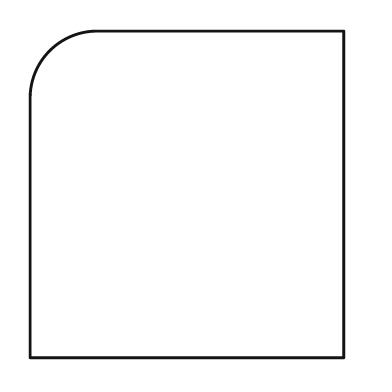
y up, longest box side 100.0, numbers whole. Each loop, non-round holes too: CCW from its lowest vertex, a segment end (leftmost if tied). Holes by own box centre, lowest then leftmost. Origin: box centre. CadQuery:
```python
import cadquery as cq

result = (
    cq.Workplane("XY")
    .moveTo(-48.0, -50.0)
    .lineTo(48.0, -50.0)
    .lineTo(48.0, 50.0)
    .lineTo(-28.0, 50.0)
    .threePointArc((-42.0, 44.0), (-48.0, 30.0))
    .close()
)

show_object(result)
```